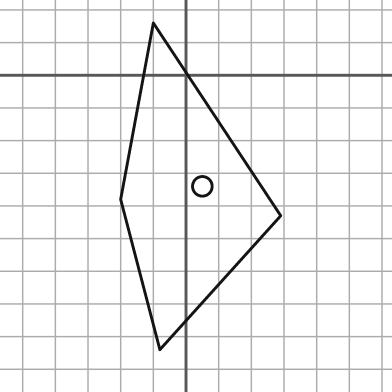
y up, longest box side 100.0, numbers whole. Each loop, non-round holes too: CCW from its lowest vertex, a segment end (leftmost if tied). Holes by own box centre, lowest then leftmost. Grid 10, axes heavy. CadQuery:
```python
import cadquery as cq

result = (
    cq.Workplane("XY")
    .moveTo(-8.0, -84.0)
    .lineTo(29.0, -43.0)
    .lineTo(-10.0, 16.0)
    .lineTo(-20.0, -38.0)
    .close()
    .moveTo(5.0, -34.0)
    .circle(3.0)
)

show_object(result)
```